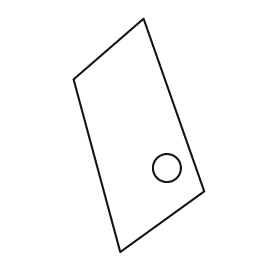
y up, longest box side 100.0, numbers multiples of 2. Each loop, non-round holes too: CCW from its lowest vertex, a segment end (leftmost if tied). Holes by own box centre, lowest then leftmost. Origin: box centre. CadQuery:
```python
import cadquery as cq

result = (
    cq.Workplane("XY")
    .moveTo(-8.0, -50.0)
    .lineTo(28.0, -24.0)
    .lineTo(2.0, 50.0)
    .lineTo(-28.0, 24.0)
    .close()
    .moveTo(12.0, -14.0)
    .circle(6.0)
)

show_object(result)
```